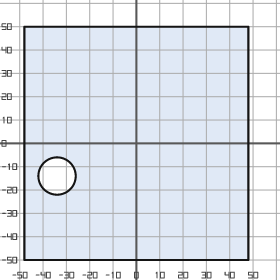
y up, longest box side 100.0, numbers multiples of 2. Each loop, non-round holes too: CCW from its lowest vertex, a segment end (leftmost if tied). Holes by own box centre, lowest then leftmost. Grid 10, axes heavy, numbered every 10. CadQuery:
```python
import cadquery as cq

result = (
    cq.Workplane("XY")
    .moveTo(-48.0, -50.0)
    .lineTo(48.0, -50.0)
    .lineTo(48.0, 50.0)
    .lineTo(-48.0, 50.0)
    .close()
    .moveTo(-34.0, -14.0)
    .circle(8.0)
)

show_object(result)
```